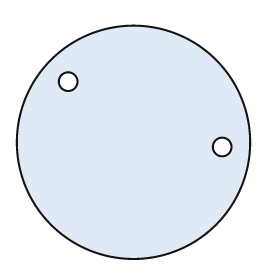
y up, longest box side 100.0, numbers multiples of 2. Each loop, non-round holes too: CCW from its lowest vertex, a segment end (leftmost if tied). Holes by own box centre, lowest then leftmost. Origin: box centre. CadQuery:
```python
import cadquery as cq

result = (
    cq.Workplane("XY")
    .moveTo(0.0, 0.0)
    .circle(50.0)
    .moveTo(38.0, -2.0)
    .circle(4.0)
    .moveTo(-28.0, 26.0)
    .circle(4.0)
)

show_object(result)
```